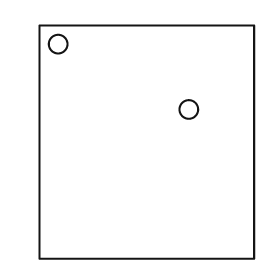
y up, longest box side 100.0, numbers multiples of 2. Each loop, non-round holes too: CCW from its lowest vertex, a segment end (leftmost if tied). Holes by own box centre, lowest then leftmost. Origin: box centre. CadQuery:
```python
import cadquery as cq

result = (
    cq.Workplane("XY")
    .moveTo(-46.0, -50.0)
    .lineTo(46.0, -50.0)
    .lineTo(46.0, 50.0)
    .lineTo(-46.0, 50.0)
    .close()
    .moveTo(18.0, 14.0)
    .circle(4.0)
    .moveTo(-38.0, 42.0)
    .circle(4.0)
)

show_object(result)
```